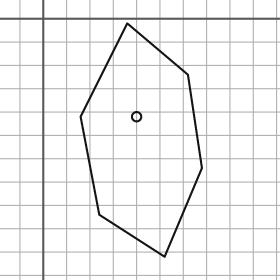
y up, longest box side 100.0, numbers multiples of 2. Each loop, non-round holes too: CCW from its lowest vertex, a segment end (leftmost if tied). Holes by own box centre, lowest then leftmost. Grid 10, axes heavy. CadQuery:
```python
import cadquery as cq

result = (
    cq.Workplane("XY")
    .moveTo(52.0, -102.0)
    .lineTo(68.0, -64.0)
    .lineTo(62.0, -24.0)
    .lineTo(36.0, -2.0)
    .lineTo(16.0, -42.0)
    .lineTo(24.0, -84.0)
    .close()
    .moveTo(40.0, -42.0)
    .circle(2.0)
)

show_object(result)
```